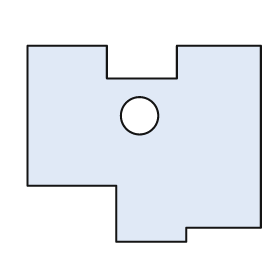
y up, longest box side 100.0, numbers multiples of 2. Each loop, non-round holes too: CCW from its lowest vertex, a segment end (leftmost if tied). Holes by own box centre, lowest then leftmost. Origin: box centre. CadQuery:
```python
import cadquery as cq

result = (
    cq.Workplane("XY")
    .moveTo(-12.0, -42.0)
    .lineTo(18.0, -42.0)
    .lineTo(18.0, -36.0)
    .lineTo(50.0, -36.0)
    .lineTo(50.0, 42.0)
    .lineTo(14.0, 42.0)
    .lineTo(14.0, 28.0)
    .lineTo(-16.0, 28.0)
    .lineTo(-16.0, 42.0)
    .lineTo(-50.0, 42.0)
    .lineTo(-50.0, -18.0)
    .lineTo(-12.0, -18.0)
    .close()
    .moveTo(-2.0, 12.0)
    .circle(8.0)
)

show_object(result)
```